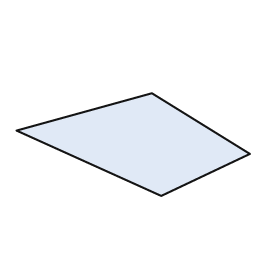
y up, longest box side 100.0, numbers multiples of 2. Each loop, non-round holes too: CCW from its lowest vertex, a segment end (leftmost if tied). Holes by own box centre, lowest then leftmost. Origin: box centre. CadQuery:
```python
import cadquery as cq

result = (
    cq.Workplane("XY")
    .moveTo(12.0, -22.0)
    .lineTo(50.0, -4.0)
    .lineTo(8.0, 22.0)
    .lineTo(-50.0, 6.0)
    .close()
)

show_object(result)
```